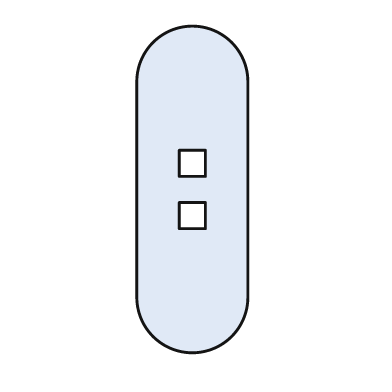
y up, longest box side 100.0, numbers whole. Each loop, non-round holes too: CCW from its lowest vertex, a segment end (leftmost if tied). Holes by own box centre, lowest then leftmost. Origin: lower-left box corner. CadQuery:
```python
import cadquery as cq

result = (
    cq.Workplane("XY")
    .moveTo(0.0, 17.0)
    .threePointArc((17.0, 0.0), (34.0, 17.0))
    .lineTo(34.0, 83.0)
    .threePointArc((17.0, 100.0), (0.0, 83.0))
    .close()
    .moveTo(13.0, 38.0)
    .lineTo(21.0, 38.0)
    .lineTo(21.0, 46.0)
    .lineTo(13.0, 46.0)
    .close()
    .moveTo(13.0, 54.0)
    .lineTo(21.0, 54.0)
    .lineTo(21.0, 62.0)
    .lineTo(13.0, 62.0)
    .close()
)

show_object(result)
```